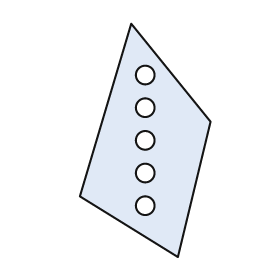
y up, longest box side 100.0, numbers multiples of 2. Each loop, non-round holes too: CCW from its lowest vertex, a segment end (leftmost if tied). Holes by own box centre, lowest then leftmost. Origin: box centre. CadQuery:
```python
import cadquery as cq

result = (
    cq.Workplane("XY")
    .moveTo(14.0, -50.0)
    .lineTo(28.0, 8.0)
    .lineTo(-6.0, 50.0)
    .lineTo(-28.0, -24.0)
    .close()
    .moveTo(0.0, -28.0)
    .circle(4.0)
    .moveTo(0.0, -14.0)
    .circle(4.0)
    .moveTo(0.0, 0.0)
    .circle(4.0)
    .moveTo(0.0, 14.0)
    .circle(4.0)
    .moveTo(0.0, 28.0)
    .circle(4.0)
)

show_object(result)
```